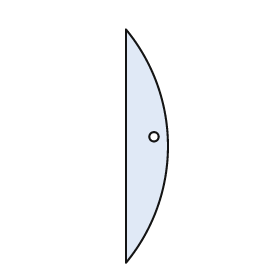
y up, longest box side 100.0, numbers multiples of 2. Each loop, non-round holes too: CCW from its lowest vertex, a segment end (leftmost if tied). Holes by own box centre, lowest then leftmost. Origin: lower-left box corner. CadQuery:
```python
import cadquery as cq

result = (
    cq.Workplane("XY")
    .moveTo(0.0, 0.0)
    .threePointArc((18.0, 50.0), (0.0, 100.0))
    .close()
    .moveTo(12.0, 54.0)
    .circle(2.0)
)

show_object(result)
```